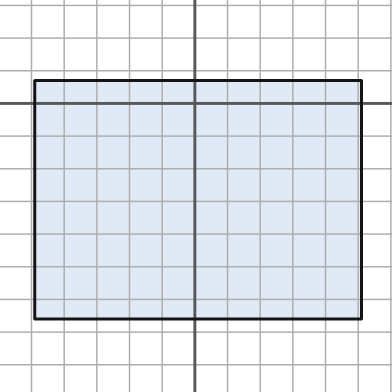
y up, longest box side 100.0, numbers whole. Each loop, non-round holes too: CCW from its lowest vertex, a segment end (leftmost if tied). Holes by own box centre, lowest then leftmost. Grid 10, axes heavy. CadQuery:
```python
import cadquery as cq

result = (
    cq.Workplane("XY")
    .moveTo(-49.0, -66.0)
    .lineTo(51.0, -66.0)
    .lineTo(51.0, 7.0)
    .lineTo(-49.0, 7.0)
    .close()
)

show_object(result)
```